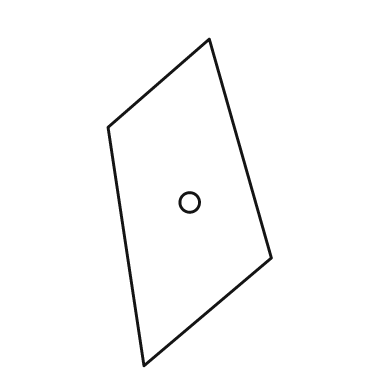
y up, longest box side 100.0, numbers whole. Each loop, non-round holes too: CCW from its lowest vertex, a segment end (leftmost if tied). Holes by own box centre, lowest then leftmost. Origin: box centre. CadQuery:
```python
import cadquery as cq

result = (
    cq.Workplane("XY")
    .moveTo(-14.0, -50.0)
    .lineTo(25.0, -17.0)
    .lineTo(6.0, 50.0)
    .lineTo(-25.0, 23.0)
    .close()
    .moveTo(0.0, 0.0)
    .circle(3.0)
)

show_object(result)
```